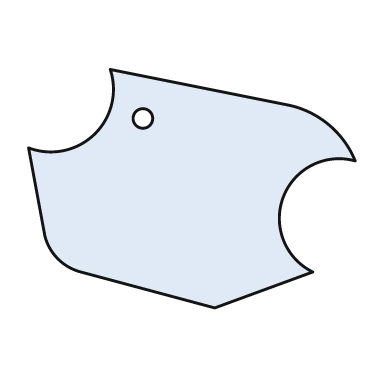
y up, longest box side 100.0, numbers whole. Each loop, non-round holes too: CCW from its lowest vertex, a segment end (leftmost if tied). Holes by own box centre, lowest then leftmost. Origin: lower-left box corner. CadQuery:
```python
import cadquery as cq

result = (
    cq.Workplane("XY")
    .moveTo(57.0, 0.0)
    .lineTo(87.0, 11.0)
    .threePointArc((78.0, 34.0), (100.0, 45.0))
    .threePointArc((92.0, 56.0), (80.0, 62.0))
    .lineTo(25.0, 73.0)
    .threePointArc((20.0, 53.0), (0.0, 49.0))
    .lineTo(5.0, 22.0)
    .threePointArc((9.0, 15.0), (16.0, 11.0))
    .close()
    .moveTo(35.0, 58.0)
    .circle(3.0)
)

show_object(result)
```